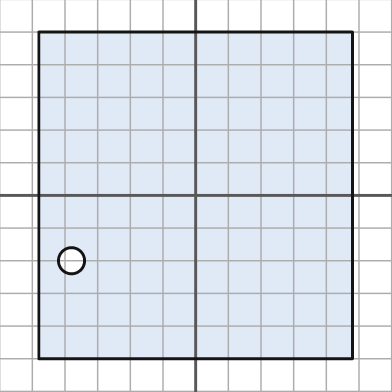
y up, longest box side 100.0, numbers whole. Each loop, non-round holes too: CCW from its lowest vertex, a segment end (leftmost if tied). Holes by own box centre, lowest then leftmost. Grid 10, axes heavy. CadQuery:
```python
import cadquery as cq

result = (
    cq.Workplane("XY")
    .moveTo(-48.0, -50.0)
    .lineTo(48.0, -50.0)
    .lineTo(48.0, 50.0)
    .lineTo(-48.0, 50.0)
    .close()
    .moveTo(-38.0, -20.0)
    .circle(4.0)
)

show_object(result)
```